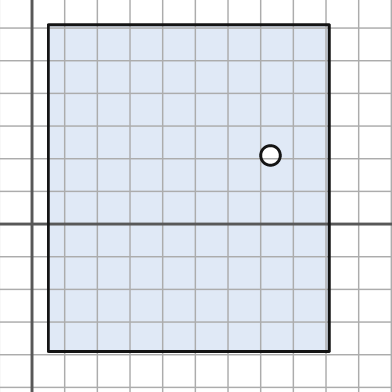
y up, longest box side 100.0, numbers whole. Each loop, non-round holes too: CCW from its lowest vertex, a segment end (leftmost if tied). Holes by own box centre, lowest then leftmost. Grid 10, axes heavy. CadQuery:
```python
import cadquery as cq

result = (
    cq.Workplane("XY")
    .moveTo(5.0, -39.0)
    .lineTo(91.0, -39.0)
    .lineTo(91.0, 61.0)
    .lineTo(5.0, 61.0)
    .close()
    .moveTo(73.0, 21.0)
    .circle(3.0)
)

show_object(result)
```